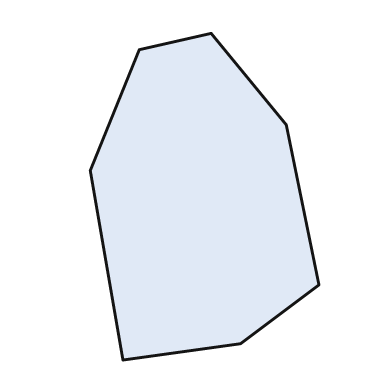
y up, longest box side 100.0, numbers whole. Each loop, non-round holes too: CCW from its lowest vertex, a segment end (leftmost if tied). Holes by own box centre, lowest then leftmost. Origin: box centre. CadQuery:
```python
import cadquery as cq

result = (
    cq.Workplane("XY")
    .moveTo(-25.0, -50.0)
    .lineTo(11.0, -45.0)
    .lineTo(35.0, -27.0)
    .lineTo(25.0, 22.0)
    .lineTo(2.0, 50.0)
    .lineTo(-20.0, 45.0)
    .lineTo(-35.0, 8.0)
    .close()
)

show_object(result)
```